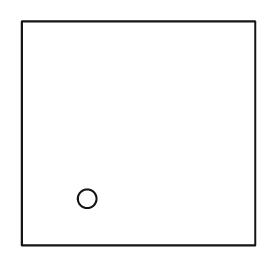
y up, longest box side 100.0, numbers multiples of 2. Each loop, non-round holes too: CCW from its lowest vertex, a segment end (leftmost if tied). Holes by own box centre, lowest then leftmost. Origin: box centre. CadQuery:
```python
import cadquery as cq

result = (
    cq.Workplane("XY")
    .moveTo(-50.0, -48.0)
    .lineTo(50.0, -48.0)
    .lineTo(50.0, 48.0)
    .lineTo(-50.0, 48.0)
    .close()
    .moveTo(-22.0, -28.0)
    .circle(4.0)
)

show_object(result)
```